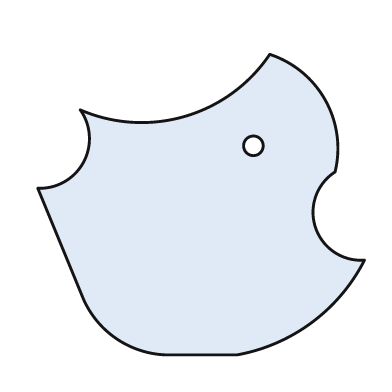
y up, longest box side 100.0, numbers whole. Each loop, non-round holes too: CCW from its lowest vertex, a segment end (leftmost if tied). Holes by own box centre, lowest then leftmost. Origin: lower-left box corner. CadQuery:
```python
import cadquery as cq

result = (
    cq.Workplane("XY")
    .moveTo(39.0, 0.0)
    .lineTo(61.0, 0.0)
    .threePointArc((84.0, 10.0), (100.0, 29.0))
    .threePointArc((85.0, 39.0), (91.0, 56.0))
    .threePointArc((88.0, 78.0), (71.0, 92.0))
    .threePointArc((45.0, 73.0), (13.0, 75.0))
    .threePointArc((14.0, 59.0), (0.0, 51.0))
    .lineTo(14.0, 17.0)
    .threePointArc((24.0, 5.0), (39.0, 0.0))
    .close()
    .moveTo(66.0, 64.0)
    .circle(3.0)
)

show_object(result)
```